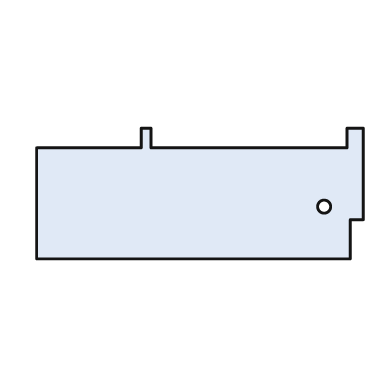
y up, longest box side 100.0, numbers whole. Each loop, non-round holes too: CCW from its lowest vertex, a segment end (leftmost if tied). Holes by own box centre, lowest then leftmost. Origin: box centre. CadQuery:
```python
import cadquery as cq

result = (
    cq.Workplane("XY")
    .moveTo(-50.0, -20.0)
    .lineTo(46.0, -20.0)
    .lineTo(46.0, -8.0)
    .lineTo(50.0, -8.0)
    .lineTo(50.0, 20.0)
    .lineTo(45.0, 20.0)
    .lineTo(45.0, 14.0)
    .lineTo(-15.0, 14.0)
    .lineTo(-15.0, 20.0)
    .lineTo(-18.0, 20.0)
    .lineTo(-18.0, 14.0)
    .lineTo(-50.0, 14.0)
    .close()
    .moveTo(38.0, -4.0)
    .circle(2.0)
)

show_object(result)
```